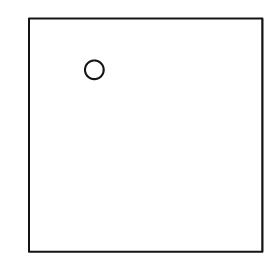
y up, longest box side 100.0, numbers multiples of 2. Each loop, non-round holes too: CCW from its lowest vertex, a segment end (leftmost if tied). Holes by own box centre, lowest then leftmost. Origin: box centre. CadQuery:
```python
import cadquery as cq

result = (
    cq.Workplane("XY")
    .moveTo(-50.0, -50.0)
    .lineTo(50.0, -50.0)
    .lineTo(50.0, 50.0)
    .lineTo(-50.0, 50.0)
    .close()
    .moveTo(-22.0, 28.0)
    .circle(4.0)
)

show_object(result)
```